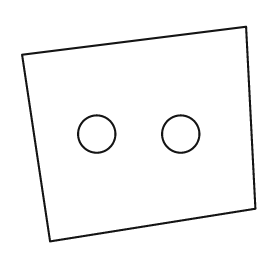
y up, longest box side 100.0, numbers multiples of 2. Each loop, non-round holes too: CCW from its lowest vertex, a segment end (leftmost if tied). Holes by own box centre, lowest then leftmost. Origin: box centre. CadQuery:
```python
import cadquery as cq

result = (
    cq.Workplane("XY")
    .moveTo(-38.0, -46.0)
    .lineTo(50.0, -32.0)
    .lineTo(46.0, 46.0)
    .lineTo(-50.0, 34.0)
    .close()
    .moveTo(-18.0, 0.0)
    .circle(8.0)
    .moveTo(18.0, 0.0)
    .circle(8.0)
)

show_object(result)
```